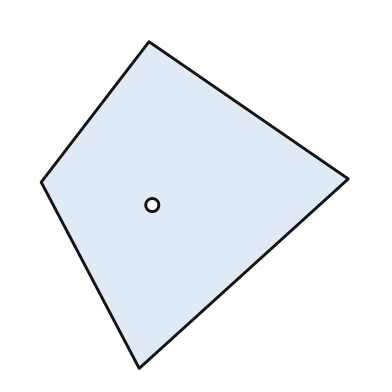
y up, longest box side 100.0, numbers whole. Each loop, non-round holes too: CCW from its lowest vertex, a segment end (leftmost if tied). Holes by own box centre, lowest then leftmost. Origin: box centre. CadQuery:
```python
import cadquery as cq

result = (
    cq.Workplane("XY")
    .moveTo(-17.0, -50.0)
    .lineTo(47.0, 8.0)
    .lineTo(-14.0, 50.0)
    .lineTo(-47.0, 7.0)
    .close()
    .moveTo(-13.0, 0.0)
    .circle(2.0)
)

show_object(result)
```